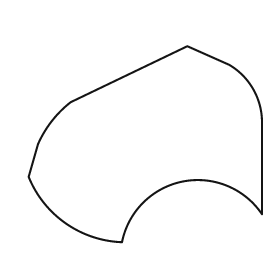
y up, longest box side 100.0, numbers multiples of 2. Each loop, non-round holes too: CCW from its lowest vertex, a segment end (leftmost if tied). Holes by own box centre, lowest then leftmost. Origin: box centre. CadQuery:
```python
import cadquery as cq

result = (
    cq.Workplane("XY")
    .moveTo(-10.0, -42.0)
    .threePointArc((16.0, -16.0), (50.0, -30.0))
    .lineTo(50.0, 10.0)
    .threePointArc((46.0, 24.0), (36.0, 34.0))
    .lineTo(18.0, 42.0)
    .lineTo(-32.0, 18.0)
    .threePointArc((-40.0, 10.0), (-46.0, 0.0))
    .lineTo(-50.0, -14.0)
    .threePointArc((-34.0, -34.0), (-10.0, -42.0))
    .close()
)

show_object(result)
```